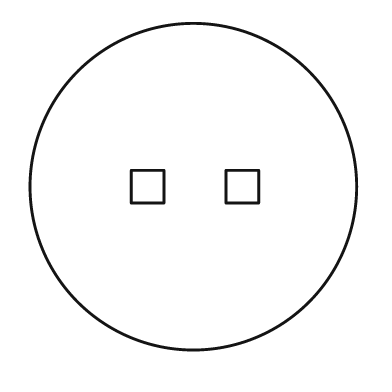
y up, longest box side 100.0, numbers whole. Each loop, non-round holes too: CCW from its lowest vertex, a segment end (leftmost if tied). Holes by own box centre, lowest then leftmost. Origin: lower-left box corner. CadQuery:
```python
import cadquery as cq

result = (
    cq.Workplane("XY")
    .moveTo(50.0, 50.0)
    .circle(50.0)
    .moveTo(31.0, 45.0)
    .lineTo(41.0, 45.0)
    .lineTo(41.0, 55.0)
    .lineTo(31.0, 55.0)
    .close()
    .moveTo(60.0, 45.0)
    .lineTo(70.0, 45.0)
    .lineTo(70.0, 55.0)
    .lineTo(60.0, 55.0)
    .close()
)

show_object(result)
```